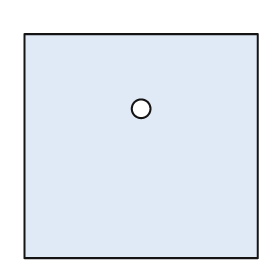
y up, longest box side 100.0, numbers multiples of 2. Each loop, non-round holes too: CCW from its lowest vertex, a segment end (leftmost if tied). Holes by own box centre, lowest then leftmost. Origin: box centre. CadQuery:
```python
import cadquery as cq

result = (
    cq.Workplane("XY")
    .moveTo(-50.0, -48.0)
    .lineTo(50.0, -48.0)
    .lineTo(50.0, 48.0)
    .lineTo(-50.0, 48.0)
    .close()
    .moveTo(0.0, 16.0)
    .circle(4.0)
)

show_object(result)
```